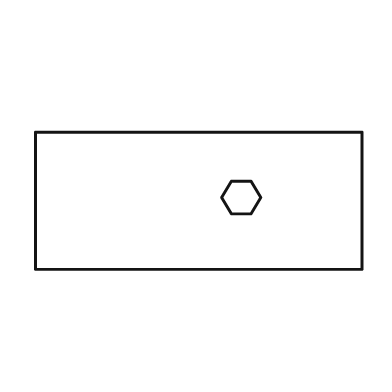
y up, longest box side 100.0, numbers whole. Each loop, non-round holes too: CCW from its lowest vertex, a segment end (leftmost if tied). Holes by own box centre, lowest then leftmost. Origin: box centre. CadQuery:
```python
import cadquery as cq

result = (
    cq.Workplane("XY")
    .moveTo(-50.0, -21.0)
    .lineTo(50.0, -21.0)
    .lineTo(50.0, 21.0)
    .lineTo(-50.0, 21.0)
    .close()
    .moveTo(10.0, -4.0)
    .lineTo(16.0, -4.0)
    .lineTo(19.0, 1.0)
    .lineTo(16.0, 6.0)
    .lineTo(10.0, 6.0)
    .lineTo(7.0, 1.0)
    .close()
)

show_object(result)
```